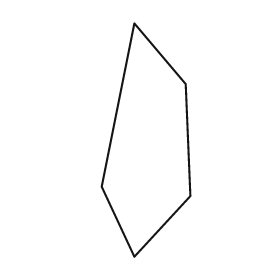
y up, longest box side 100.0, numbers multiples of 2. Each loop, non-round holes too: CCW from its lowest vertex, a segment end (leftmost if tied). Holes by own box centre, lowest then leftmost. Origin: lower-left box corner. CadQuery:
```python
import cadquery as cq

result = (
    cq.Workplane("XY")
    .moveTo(14.0, 0.0)
    .lineTo(38.0, 26.0)
    .lineTo(36.0, 74.0)
    .lineTo(14.0, 100.0)
    .lineTo(0.0, 30.0)
    .close()
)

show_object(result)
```